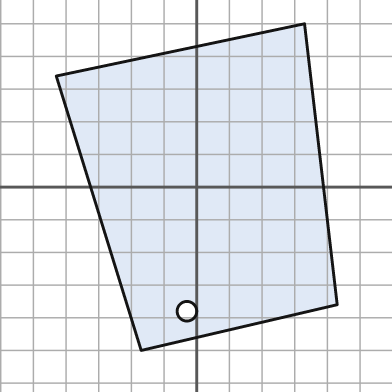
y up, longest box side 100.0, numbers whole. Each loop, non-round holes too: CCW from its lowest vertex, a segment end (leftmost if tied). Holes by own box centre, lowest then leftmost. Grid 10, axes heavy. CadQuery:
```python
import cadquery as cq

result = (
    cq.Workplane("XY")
    .moveTo(-17.0, -50.0)
    .lineTo(43.0, -36.0)
    .lineTo(33.0, 50.0)
    .lineTo(-43.0, 34.0)
    .close()
    .moveTo(-3.0, -38.0)
    .circle(3.0)
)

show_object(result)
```